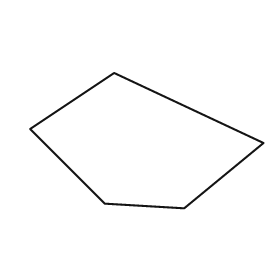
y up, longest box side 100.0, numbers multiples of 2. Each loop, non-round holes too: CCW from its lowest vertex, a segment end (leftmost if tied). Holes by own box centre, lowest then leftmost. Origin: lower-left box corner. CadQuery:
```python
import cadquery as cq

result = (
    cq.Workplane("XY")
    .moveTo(66.0, 0.0)
    .lineTo(100.0, 28.0)
    .lineTo(36.0, 58.0)
    .lineTo(0.0, 34.0)
    .lineTo(32.0, 2.0)
    .close()
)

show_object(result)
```